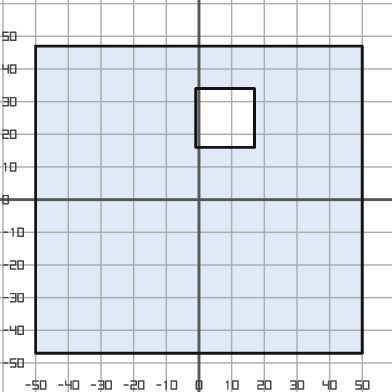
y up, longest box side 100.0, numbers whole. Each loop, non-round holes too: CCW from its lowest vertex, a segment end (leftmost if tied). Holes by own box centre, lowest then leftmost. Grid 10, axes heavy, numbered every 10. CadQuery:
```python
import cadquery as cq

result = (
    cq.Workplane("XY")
    .moveTo(-50.0, -47.0)
    .lineTo(50.0, -47.0)
    .lineTo(50.0, 47.0)
    .lineTo(-50.0, 47.0)
    .close()
    .moveTo(-1.0, 16.0)
    .lineTo(17.0, 16.0)
    .lineTo(17.0, 34.0)
    .lineTo(-1.0, 34.0)
    .close()
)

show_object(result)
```